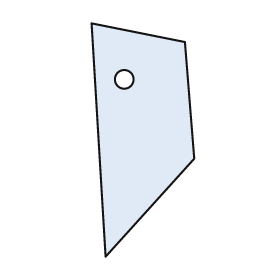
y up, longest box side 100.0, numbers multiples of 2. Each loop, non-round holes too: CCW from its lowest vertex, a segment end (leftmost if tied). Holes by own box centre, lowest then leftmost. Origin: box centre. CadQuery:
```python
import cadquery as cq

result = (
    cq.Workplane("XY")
    .moveTo(-16.0, -50.0)
    .lineTo(22.0, -8.0)
    .lineTo(18.0, 42.0)
    .lineTo(-22.0, 50.0)
    .close()
    .moveTo(-8.0, 26.0)
    .circle(4.0)
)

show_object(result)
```